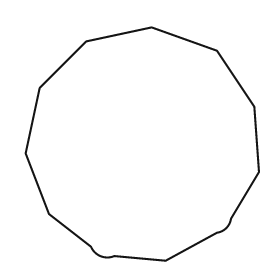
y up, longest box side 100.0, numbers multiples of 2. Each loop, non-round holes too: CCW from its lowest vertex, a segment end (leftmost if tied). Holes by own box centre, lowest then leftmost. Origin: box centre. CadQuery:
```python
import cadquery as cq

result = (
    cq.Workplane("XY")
    .moveTo(10.0, -50.0)
    .lineTo(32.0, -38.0)
    .threePointArc((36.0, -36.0), (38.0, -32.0))
    .lineTo(50.0, -12.0)
    .lineTo(48.0, 16.0)
    .lineTo(32.0, 40.0)
    .lineTo(4.0, 50.0)
    .lineTo(-24.0, 44.0)
    .lineTo(-44.0, 24.0)
    .lineTo(-50.0, -4.0)
    .lineTo(-40.0, -30.0)
    .lineTo(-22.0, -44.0)
    .threePointArc((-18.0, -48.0), (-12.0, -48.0))
    .close()
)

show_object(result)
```